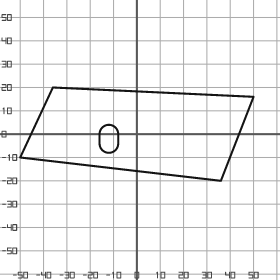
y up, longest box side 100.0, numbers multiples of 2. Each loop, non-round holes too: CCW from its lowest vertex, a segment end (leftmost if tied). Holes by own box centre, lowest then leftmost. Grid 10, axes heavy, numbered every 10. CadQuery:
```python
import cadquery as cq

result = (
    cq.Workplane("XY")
    .moveTo(36.0, -20.0)
    .lineTo(50.0, 16.0)
    .lineTo(-36.0, 20.0)
    .lineTo(-50.0, -10.0)
    .close()
    .moveTo(-16.0, -4.0)
    .threePointArc((-12.0, -8.0), (-8.0, -4.0))
    .lineTo(-8.0, 0.0)
    .threePointArc((-12.0, 4.0), (-16.0, 0.0))
    .close()
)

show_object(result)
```